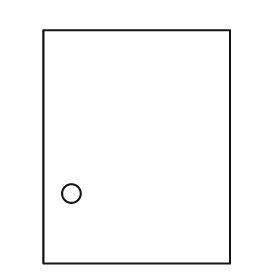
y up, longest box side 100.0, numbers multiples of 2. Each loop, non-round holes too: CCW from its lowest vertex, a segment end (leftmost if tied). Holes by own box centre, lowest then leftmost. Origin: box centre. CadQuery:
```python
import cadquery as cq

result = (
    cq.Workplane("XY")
    .moveTo(-40.0, -50.0)
    .lineTo(40.0, -50.0)
    .lineTo(40.0, 50.0)
    .lineTo(-40.0, 50.0)
    .close()
    .moveTo(-28.0, -20.0)
    .circle(4.0)
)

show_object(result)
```